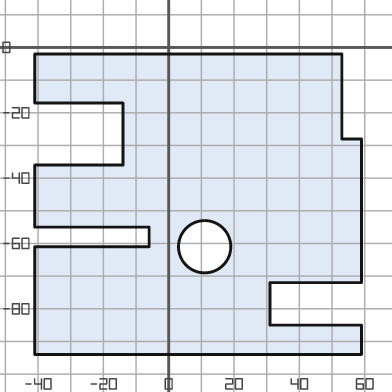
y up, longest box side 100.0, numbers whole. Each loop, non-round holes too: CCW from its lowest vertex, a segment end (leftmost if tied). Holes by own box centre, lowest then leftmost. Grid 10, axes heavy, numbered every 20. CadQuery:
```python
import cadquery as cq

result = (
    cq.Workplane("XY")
    .moveTo(-41.0, -94.0)
    .lineTo(59.0, -94.0)
    .lineTo(59.0, -85.0)
    .lineTo(31.0, -85.0)
    .lineTo(31.0, -72.0)
    .lineTo(59.0, -72.0)
    .lineTo(59.0, -28.0)
    .lineTo(53.0, -28.0)
    .lineTo(53.0, -2.0)
    .lineTo(-41.0, -2.0)
    .lineTo(-41.0, -17.0)
    .lineTo(-14.0, -17.0)
    .lineTo(-14.0, -36.0)
    .lineTo(-41.0, -36.0)
    .lineTo(-41.0, -55.0)
    .lineTo(-6.0, -55.0)
    .lineTo(-6.0, -61.0)
    .lineTo(-41.0, -61.0)
    .close()
    .moveTo(11.0, -61.0)
    .circle(8.0)
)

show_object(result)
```